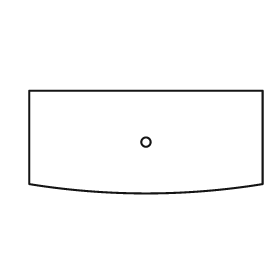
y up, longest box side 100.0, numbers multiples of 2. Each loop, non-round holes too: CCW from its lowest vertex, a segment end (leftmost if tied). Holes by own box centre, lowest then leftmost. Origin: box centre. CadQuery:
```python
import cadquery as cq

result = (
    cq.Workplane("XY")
    .moveTo(-50.0, -18.0)
    .threePointArc((0.0, -22.0), (50.0, -18.0))
    .lineTo(50.0, 22.0)
    .lineTo(-50.0, 22.0)
    .close()
    .moveTo(0.0, 0.0)
    .circle(2.0)
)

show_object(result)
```